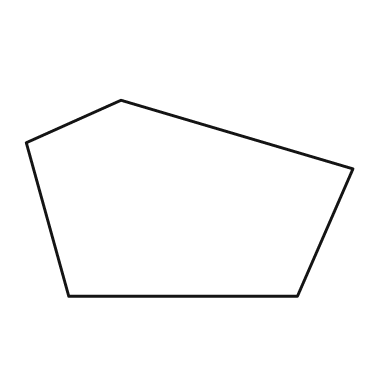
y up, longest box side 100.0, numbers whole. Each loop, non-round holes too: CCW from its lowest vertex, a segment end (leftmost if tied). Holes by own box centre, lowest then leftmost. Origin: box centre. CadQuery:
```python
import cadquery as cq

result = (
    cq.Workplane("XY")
    .moveTo(-37.0, -30.0)
    .lineTo(33.0, -30.0)
    .lineTo(50.0, 9.0)
    .lineTo(-21.0, 30.0)
    .lineTo(-50.0, 17.0)
    .close()
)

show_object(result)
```